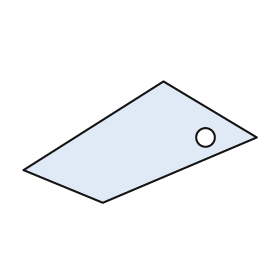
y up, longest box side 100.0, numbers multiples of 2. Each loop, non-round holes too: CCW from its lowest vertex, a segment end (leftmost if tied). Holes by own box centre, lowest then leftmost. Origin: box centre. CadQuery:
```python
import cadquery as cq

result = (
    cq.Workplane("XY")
    .moveTo(-16.0, -26.0)
    .lineTo(50.0, 2.0)
    .lineTo(10.0, 26.0)
    .lineTo(-50.0, -12.0)
    .close()
    .moveTo(28.0, 2.0)
    .circle(4.0)
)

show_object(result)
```